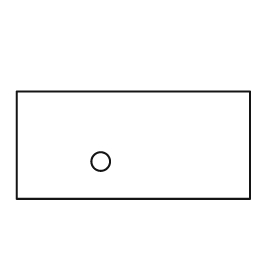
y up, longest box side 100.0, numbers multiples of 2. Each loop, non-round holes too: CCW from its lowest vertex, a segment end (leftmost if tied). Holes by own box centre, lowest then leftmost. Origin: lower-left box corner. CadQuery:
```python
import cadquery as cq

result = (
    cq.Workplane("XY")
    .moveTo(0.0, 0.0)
    .lineTo(100.0, 0.0)
    .lineTo(100.0, 46.0)
    .lineTo(0.0, 46.0)
    .close()
    .moveTo(36.0, 16.0)
    .circle(4.0)
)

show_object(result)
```